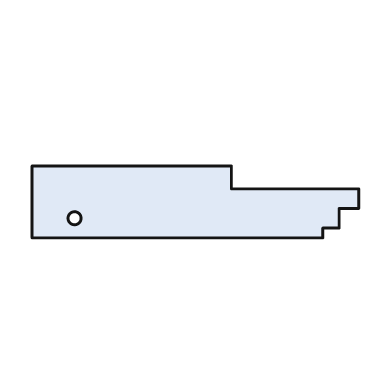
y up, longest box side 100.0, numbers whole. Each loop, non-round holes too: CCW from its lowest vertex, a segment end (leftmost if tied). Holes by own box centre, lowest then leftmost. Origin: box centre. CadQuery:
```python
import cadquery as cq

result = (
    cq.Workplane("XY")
    .moveTo(-50.0, -11.0)
    .lineTo(39.0, -11.0)
    .lineTo(39.0, -8.0)
    .lineTo(44.0, -8.0)
    .lineTo(44.0, -2.0)
    .lineTo(50.0, -2.0)
    .lineTo(50.0, 4.0)
    .lineTo(11.0, 4.0)
    .lineTo(11.0, 11.0)
    .lineTo(-50.0, 11.0)
    .close()
    .moveTo(-37.0, -5.0)
    .circle(2.0)
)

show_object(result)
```